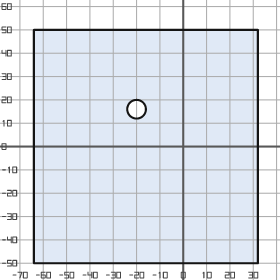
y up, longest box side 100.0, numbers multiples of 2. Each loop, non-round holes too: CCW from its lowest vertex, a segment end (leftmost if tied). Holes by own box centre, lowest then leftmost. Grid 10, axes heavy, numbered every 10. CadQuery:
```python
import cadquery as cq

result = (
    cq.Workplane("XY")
    .moveTo(-64.0, -50.0)
    .lineTo(32.0, -50.0)
    .lineTo(32.0, 50.0)
    .lineTo(-64.0, 50.0)
    .close()
    .moveTo(-20.0, 16.0)
    .circle(4.0)
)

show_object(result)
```